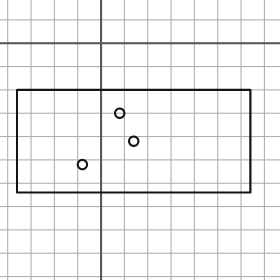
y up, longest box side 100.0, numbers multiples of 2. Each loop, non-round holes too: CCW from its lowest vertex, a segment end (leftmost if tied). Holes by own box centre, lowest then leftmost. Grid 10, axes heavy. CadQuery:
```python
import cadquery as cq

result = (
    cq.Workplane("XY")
    .moveTo(-36.0, -64.0)
    .lineTo(64.0, -64.0)
    .lineTo(64.0, -20.0)
    .lineTo(-36.0, -20.0)
    .close()
    .moveTo(-8.0, -52.0)
    .circle(2.0)
    .moveTo(14.0, -42.0)
    .circle(2.0)
    .moveTo(8.0, -30.0)
    .circle(2.0)
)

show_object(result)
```